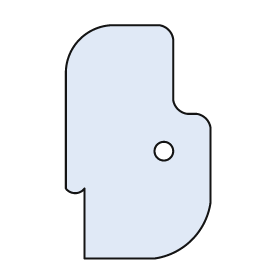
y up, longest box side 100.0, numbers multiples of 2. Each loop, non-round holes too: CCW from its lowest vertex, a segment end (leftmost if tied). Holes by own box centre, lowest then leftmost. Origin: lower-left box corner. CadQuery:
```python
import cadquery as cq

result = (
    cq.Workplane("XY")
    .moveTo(8.0, 0.0)
    .lineTo(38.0, 0.0)
    .threePointArc((54.0, 8.0), (62.0, 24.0))
    .lineTo(62.0, 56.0)
    .threePointArc((60.0, 60.0), (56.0, 62.0))
    .lineTo(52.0, 62.0)
    .threePointArc((48.0, 64.0), (46.0, 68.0))
    .lineTo(46.0, 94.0)
    .threePointArc((44.0, 98.0), (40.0, 100.0))
    .lineTo(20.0, 100.0)
    .threePointArc((6.0, 94.0), (0.0, 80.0))
    .lineTo(0.0, 30.0)
    .threePointArc((4.0, 28.0), (8.0, 30.0))
    .close()
    .moveTo(42.0, 46.0)
    .circle(4.0)
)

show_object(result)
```